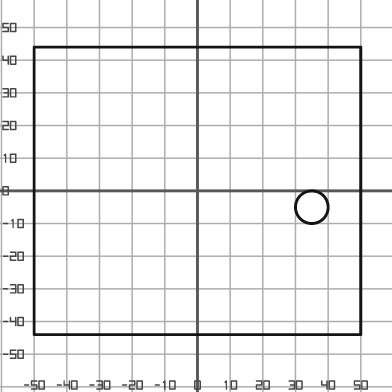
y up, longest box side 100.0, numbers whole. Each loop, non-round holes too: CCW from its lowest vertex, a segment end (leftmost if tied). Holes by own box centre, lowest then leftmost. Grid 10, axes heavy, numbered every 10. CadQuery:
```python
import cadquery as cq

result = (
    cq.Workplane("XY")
    .moveTo(-50.0, -44.0)
    .lineTo(50.0, -44.0)
    .lineTo(50.0, 44.0)
    .lineTo(-50.0, 44.0)
    .close()
    .moveTo(35.0, -5.0)
    .circle(5.0)
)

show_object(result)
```